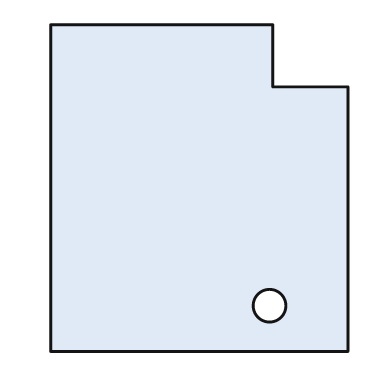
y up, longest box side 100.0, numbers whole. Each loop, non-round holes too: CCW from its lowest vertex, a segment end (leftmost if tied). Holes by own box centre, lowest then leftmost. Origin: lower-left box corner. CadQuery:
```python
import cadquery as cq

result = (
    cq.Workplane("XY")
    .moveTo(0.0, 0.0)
    .lineTo(91.0, 0.0)
    .lineTo(91.0, 81.0)
    .lineTo(68.0, 81.0)
    .lineTo(68.0, 100.0)
    .lineTo(0.0, 100.0)
    .close()
    .moveTo(67.0, 14.0)
    .circle(5.0)
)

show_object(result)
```